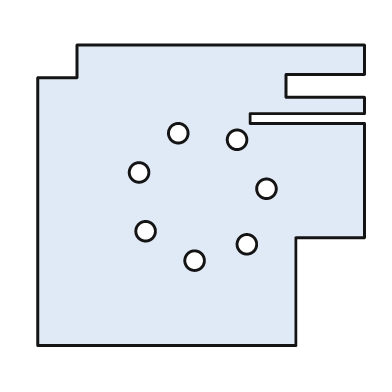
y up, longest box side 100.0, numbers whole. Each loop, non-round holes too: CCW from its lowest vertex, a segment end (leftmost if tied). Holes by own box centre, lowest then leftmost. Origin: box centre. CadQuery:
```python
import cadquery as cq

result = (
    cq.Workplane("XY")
    .moveTo(-50.0, -46.0)
    .lineTo(29.0, -46.0)
    .lineTo(29.0, -13.0)
    .lineTo(50.0, -13.0)
    .lineTo(50.0, 22.0)
    .lineTo(15.0, 22.0)
    .lineTo(15.0, 25.0)
    .lineTo(50.0, 25.0)
    .lineTo(50.0, 30.0)
    .lineTo(26.0, 30.0)
    .lineTo(26.0, 37.0)
    .lineTo(50.0, 37.0)
    .lineTo(50.0, 46.0)
    .lineTo(-38.0, 46.0)
    .lineTo(-38.0, 36.0)
    .lineTo(-50.0, 36.0)
    .close()
    .moveTo(-2.0, -20.0)
    .circle(3.0)
    .moveTo(14.0, -15.0)
    .circle(3.0)
    .moveTo(-17.0, -11.0)
    .circle(3.0)
    .moveTo(20.0, 2.0)
    .circle(3.0)
    .moveTo(-19.0, 7.0)
    .circle(3.0)
    .moveTo(11.0, 17.0)
    .circle(3.0)
    .moveTo(-7.0, 19.0)
    .circle(3.0)
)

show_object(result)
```